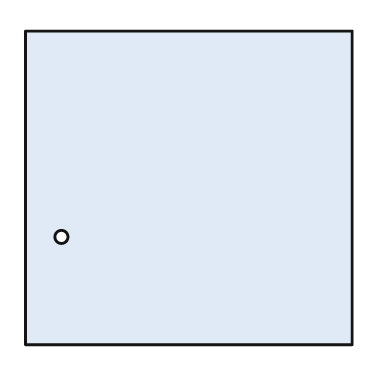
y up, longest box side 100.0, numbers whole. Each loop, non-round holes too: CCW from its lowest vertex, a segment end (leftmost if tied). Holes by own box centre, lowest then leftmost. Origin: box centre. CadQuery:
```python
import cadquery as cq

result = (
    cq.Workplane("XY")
    .moveTo(-50.0, -48.0)
    .lineTo(50.0, -48.0)
    .lineTo(50.0, 48.0)
    .lineTo(-50.0, 48.0)
    .close()
    .moveTo(-39.0, -15.0)
    .circle(2.0)
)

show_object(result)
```